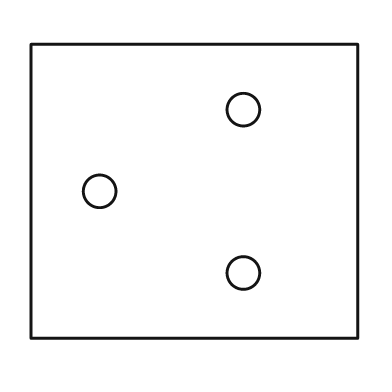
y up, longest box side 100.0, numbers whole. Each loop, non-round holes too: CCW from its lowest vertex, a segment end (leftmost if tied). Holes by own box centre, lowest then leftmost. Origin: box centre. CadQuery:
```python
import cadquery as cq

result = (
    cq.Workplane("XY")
    .moveTo(-50.0, -45.0)
    .lineTo(50.0, -45.0)
    .lineTo(50.0, 45.0)
    .lineTo(-50.0, 45.0)
    .close()
    .moveTo(15.0, -25.0)
    .circle(5.0)
    .moveTo(-29.0, 0.0)
    .circle(5.0)
    .moveTo(15.0, 25.0)
    .circle(5.0)
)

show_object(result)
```